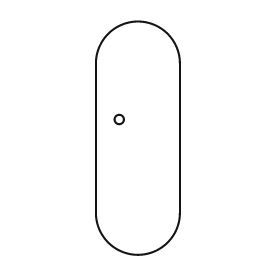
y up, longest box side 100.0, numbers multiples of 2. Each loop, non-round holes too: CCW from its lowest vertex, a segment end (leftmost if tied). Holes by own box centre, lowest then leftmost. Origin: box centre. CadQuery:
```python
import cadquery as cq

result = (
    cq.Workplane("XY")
    .moveTo(-18.0, -32.0)
    .threePointArc((0.0, -50.0), (18.0, -32.0))
    .lineTo(18.0, 32.0)
    .threePointArc((0.0, 50.0), (-18.0, 32.0))
    .close()
    .moveTo(-8.0, 8.0)
    .circle(2.0)
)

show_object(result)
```